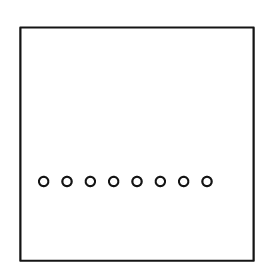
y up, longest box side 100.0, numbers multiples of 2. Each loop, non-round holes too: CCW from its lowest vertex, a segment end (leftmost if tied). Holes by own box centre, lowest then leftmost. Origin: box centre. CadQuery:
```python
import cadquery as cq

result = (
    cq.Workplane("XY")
    .moveTo(-50.0, -50.0)
    .lineTo(50.0, -50.0)
    .lineTo(50.0, 50.0)
    .lineTo(-50.0, 50.0)
    .close()
    .moveTo(-40.0, -16.0)
    .circle(2.0)
    .moveTo(-30.0, -16.0)
    .circle(2.0)
    .moveTo(-20.0, -16.0)
    .circle(2.0)
    .moveTo(-10.0, -16.0)
    .circle(2.0)
    .moveTo(0.0, -16.0)
    .circle(2.0)
    .moveTo(10.0, -16.0)
    .circle(2.0)
    .moveTo(20.0, -16.0)
    .circle(2.0)
    .moveTo(30.0, -16.0)
    .circle(2.0)
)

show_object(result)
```